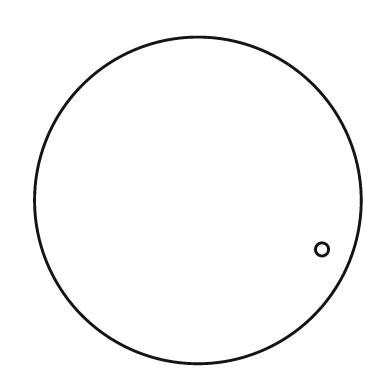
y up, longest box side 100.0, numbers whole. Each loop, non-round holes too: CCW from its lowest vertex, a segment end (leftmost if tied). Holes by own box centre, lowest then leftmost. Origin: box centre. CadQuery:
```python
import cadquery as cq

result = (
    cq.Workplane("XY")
    .moveTo(0.0, 0.0)
    .circle(50.0)
    .moveTo(38.0, -15.0)
    .circle(2.0)
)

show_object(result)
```